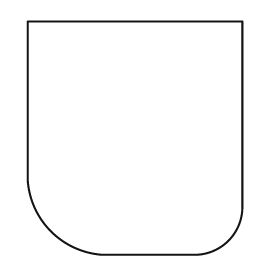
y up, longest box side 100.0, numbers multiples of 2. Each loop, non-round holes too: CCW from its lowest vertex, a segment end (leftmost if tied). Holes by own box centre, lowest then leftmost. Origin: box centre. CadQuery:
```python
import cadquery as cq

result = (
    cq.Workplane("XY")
    .moveTo(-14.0, -50.0)
    .lineTo(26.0, -50.0)
    .threePointArc((40.0, -44.0), (46.0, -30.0))
    .lineTo(46.0, 50.0)
    .lineTo(-46.0, 50.0)
    .lineTo(-46.0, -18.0)
    .threePointArc((-36.0, -40.0), (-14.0, -50.0))
    .close()
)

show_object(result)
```